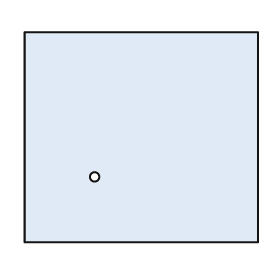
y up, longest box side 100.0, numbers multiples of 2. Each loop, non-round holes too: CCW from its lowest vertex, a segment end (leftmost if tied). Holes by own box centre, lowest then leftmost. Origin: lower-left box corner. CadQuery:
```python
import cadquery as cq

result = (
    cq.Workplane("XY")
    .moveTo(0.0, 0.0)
    .lineTo(100.0, 0.0)
    .lineTo(100.0, 90.0)
    .lineTo(0.0, 90.0)
    .close()
    .moveTo(30.0, 28.0)
    .circle(2.0)
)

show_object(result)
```